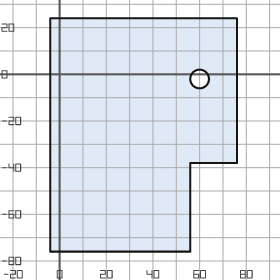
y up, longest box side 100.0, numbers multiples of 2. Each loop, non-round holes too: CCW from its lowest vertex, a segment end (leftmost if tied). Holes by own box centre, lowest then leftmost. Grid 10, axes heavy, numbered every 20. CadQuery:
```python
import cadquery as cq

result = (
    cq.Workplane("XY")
    .moveTo(-4.0, -76.0)
    .lineTo(56.0, -76.0)
    .lineTo(56.0, -38.0)
    .lineTo(76.0, -38.0)
    .lineTo(76.0, 24.0)
    .lineTo(-4.0, 24.0)
    .close()
    .moveTo(60.0, -2.0)
    .circle(4.0)
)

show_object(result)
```